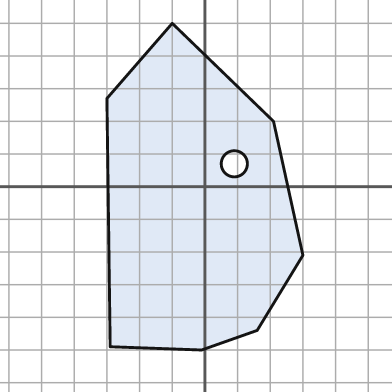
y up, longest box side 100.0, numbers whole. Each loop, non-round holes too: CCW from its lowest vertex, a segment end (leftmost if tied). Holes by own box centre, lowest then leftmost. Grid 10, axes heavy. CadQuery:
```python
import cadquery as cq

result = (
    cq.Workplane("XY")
    .moveTo(-1.0, -50.0)
    .lineTo(16.0, -44.0)
    .lineTo(30.0, -21.0)
    .lineTo(21.0, 20.0)
    .lineTo(-10.0, 50.0)
    .lineTo(-30.0, 27.0)
    .lineTo(-29.0, -49.0)
    .close()
    .moveTo(9.0, 7.0)
    .circle(4.0)
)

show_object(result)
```